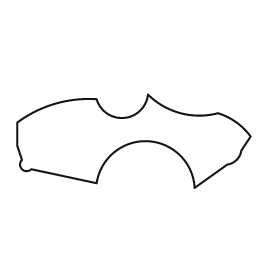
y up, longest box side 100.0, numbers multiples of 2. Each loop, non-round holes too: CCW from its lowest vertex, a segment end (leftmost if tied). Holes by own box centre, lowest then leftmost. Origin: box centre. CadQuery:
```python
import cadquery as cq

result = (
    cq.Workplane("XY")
    .moveTo(26.0, -20.0)
    .lineTo(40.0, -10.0)
    .threePointArc((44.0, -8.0), (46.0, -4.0))
    .lineTo(50.0, 2.0)
    .threePointArc((44.0, 8.0), (36.0, 12.0))
    .threePointArc((20.0, 12.0), (6.0, 20.0))
    .threePointArc((-4.0, 10.0), (-16.0, 18.0))
    .threePointArc((-34.0, 16.0), (-50.0, 8.0))
    .lineTo(-50.0, -2.0)
    .lineTo(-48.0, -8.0)
    .threePointArc((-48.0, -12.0), (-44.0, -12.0))
    .lineTo(-16.0, -18.0)
    .threePointArc((6.0, 0.0), (26.0, -20.0))
    .close()
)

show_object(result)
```